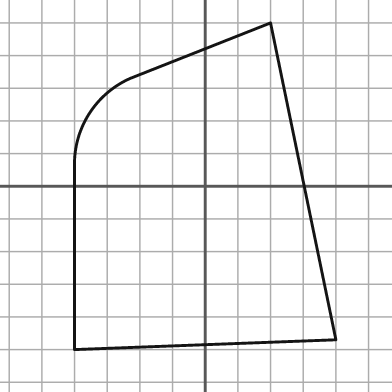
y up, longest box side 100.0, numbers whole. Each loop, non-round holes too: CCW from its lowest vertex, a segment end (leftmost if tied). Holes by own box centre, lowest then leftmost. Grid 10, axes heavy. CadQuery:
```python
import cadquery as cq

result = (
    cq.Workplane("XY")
    .moveTo(-40.0, -50.0)
    .lineTo(40.0, -47.0)
    .lineTo(20.0, 50.0)
    .lineTo(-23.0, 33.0)
    .threePointArc((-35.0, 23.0), (-40.0, 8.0))
    .close()
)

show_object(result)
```